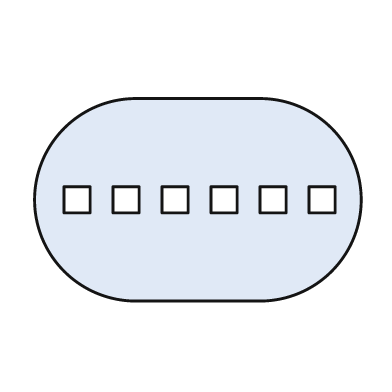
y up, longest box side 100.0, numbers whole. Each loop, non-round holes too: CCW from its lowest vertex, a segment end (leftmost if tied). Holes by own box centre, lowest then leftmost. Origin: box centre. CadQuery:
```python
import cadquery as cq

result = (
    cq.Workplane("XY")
    .moveTo(-19.0, -31.0)
    .lineTo(19.0, -31.0)
    .threePointArc((50.0, 0.0), (19.0, 31.0))
    .lineTo(-19.0, 31.0)
    .threePointArc((-50.0, 0.0), (-19.0, -31.0))
    .close()
    .moveTo(-41.0, -4.0)
    .lineTo(-33.0, -4.0)
    .lineTo(-33.0, 4.0)
    .lineTo(-41.0, 4.0)
    .close()
    .moveTo(-26.0, -4.0)
    .lineTo(-18.0, -4.0)
    .lineTo(-18.0, 4.0)
    .lineTo(-26.0, 4.0)
    .close()
    .moveTo(-11.0, -4.0)
    .lineTo(-3.0, -4.0)
    .lineTo(-3.0, 4.0)
    .lineTo(-11.0, 4.0)
    .close()
    .moveTo(4.0, -4.0)
    .lineTo(12.0, -4.0)
    .lineTo(12.0, 4.0)
    .lineTo(4.0, 4.0)
    .close()
    .moveTo(19.0, -4.0)
    .lineTo(27.0, -4.0)
    .lineTo(27.0, 4.0)
    .lineTo(19.0, 4.0)
    .close()
    .moveTo(34.0, -4.0)
    .lineTo(42.0, -4.0)
    .lineTo(42.0, 4.0)
    .lineTo(34.0, 4.0)
    .close()
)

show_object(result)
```